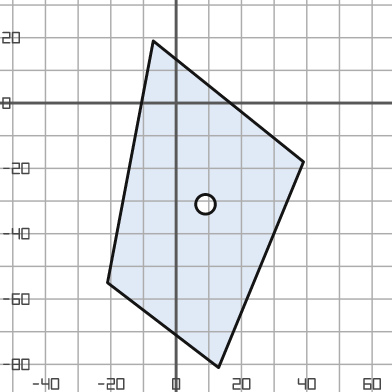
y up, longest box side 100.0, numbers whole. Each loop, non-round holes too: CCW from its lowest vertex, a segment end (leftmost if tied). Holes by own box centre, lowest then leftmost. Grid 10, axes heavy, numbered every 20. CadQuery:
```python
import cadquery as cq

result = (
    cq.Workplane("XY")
    .moveTo(13.0, -81.0)
    .lineTo(39.0, -18.0)
    .lineTo(-7.0, 19.0)
    .lineTo(-21.0, -55.0)
    .close()
    .moveTo(9.0, -31.0)
    .circle(3.0)
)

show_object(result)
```